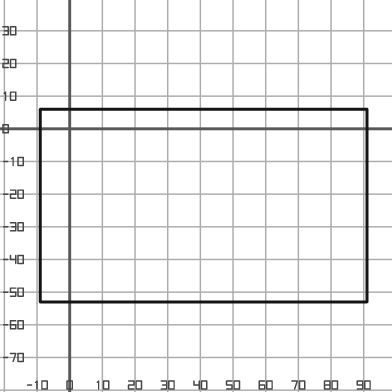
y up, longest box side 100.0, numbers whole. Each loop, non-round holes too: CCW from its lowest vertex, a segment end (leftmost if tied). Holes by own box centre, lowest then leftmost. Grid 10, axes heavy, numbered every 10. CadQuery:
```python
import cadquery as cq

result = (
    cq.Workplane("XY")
    .moveTo(-9.0, -53.0)
    .lineTo(91.0, -53.0)
    .lineTo(91.0, 6.0)
    .lineTo(-9.0, 6.0)
    .close()
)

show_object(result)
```